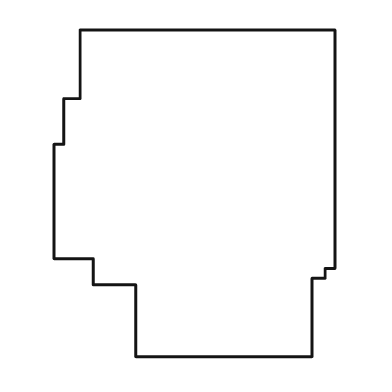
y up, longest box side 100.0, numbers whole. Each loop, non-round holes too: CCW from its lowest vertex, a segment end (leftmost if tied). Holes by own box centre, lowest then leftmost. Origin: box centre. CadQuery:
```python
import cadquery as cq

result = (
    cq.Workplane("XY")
    .moveTo(-18.0, -50.0)
    .lineTo(36.0, -50.0)
    .lineTo(36.0, -26.0)
    .lineTo(40.0, -26.0)
    .lineTo(40.0, -23.0)
    .lineTo(43.0, -23.0)
    .lineTo(43.0, 50.0)
    .lineTo(-35.0, 50.0)
    .lineTo(-35.0, 29.0)
    .lineTo(-40.0, 29.0)
    .lineTo(-40.0, 15.0)
    .lineTo(-43.0, 15.0)
    .lineTo(-43.0, -20.0)
    .lineTo(-31.0, -20.0)
    .lineTo(-31.0, -28.0)
    .lineTo(-18.0, -28.0)
    .close()
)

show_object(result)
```